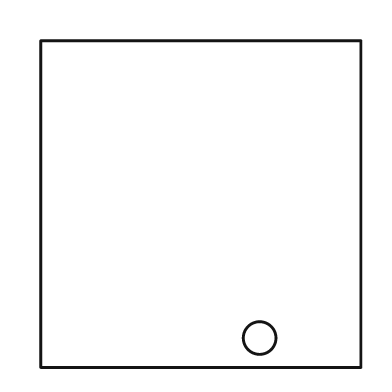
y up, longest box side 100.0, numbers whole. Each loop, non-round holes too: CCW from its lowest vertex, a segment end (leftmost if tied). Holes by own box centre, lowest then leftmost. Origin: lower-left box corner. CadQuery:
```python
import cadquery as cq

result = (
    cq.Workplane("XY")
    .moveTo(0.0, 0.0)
    .lineTo(98.0, 0.0)
    .lineTo(98.0, 100.0)
    .lineTo(0.0, 100.0)
    .close()
    .moveTo(67.0, 9.0)
    .circle(5.0)
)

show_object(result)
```